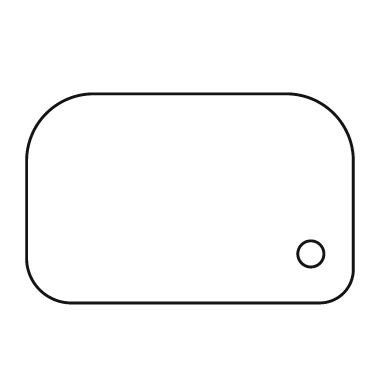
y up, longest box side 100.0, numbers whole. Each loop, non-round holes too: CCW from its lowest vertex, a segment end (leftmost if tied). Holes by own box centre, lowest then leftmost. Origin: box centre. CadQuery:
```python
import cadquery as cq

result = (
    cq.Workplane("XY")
    .moveTo(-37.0, -32.0)
    .lineTo(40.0, -32.0)
    .threePointArc((47.0, -29.0), (50.0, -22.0))
    .lineTo(50.0, 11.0)
    .threePointArc((44.0, 26.0), (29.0, 32.0))
    .lineTo(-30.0, 32.0)
    .threePointArc((-44.0, 26.0), (-50.0, 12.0))
    .lineTo(-50.0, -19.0)
    .threePointArc((-46.0, -28.0), (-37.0, -32.0))
    .close()
    .moveTo(37.0, -17.0)
    .circle(4.0)
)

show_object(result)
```